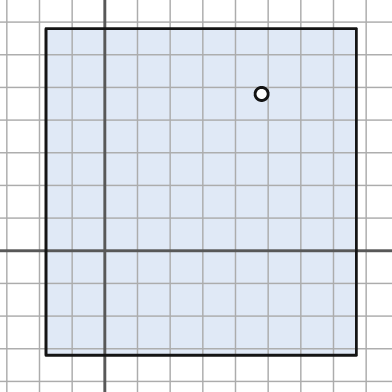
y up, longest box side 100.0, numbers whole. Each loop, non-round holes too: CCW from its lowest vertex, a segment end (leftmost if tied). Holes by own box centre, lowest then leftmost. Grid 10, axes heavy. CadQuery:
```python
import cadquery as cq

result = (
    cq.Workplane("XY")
    .moveTo(-18.0, -32.0)
    .lineTo(77.0, -32.0)
    .lineTo(77.0, 68.0)
    .lineTo(-18.0, 68.0)
    .close()
    .moveTo(48.0, 48.0)
    .circle(2.0)
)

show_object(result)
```